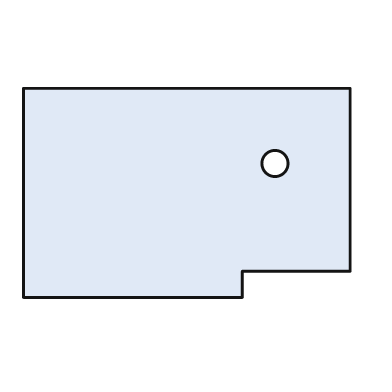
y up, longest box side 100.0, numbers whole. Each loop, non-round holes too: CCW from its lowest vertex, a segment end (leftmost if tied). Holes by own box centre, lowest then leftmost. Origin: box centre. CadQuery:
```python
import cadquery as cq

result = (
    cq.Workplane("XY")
    .moveTo(-50.0, -32.0)
    .lineTo(17.0, -32.0)
    .lineTo(17.0, -24.0)
    .lineTo(50.0, -24.0)
    .lineTo(50.0, 32.0)
    .lineTo(-50.0, 32.0)
    .close()
    .moveTo(27.0, 9.0)
    .circle(4.0)
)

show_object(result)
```